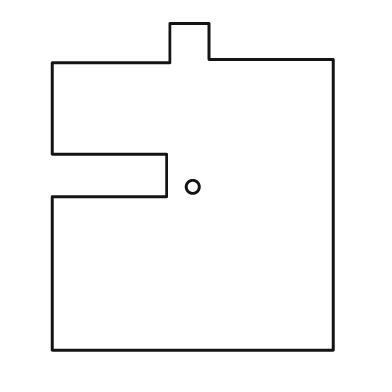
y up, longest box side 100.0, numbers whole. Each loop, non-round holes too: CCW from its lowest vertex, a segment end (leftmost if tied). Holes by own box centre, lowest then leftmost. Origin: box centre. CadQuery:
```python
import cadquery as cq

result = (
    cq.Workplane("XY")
    .moveTo(-43.0, -50.0)
    .lineTo(43.0, -50.0)
    .lineTo(43.0, 39.0)
    .lineTo(5.0, 39.0)
    .lineTo(5.0, 50.0)
    .lineTo(-7.0, 50.0)
    .lineTo(-7.0, 38.0)
    .lineTo(-43.0, 38.0)
    .lineTo(-43.0, 10.0)
    .lineTo(-8.0, 10.0)
    .lineTo(-8.0, -3.0)
    .lineTo(-43.0, -3.0)
    .close()
    .moveTo(0.0, 0.0)
    .circle(2.0)
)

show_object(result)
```